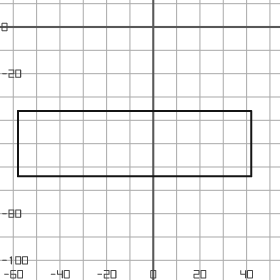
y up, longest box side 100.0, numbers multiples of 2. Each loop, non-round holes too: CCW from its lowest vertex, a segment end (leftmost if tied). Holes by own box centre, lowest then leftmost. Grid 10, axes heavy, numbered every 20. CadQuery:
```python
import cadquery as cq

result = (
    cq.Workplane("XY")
    .moveTo(-58.0, -64.0)
    .lineTo(42.0, -64.0)
    .lineTo(42.0, -36.0)
    .lineTo(-58.0, -36.0)
    .close()
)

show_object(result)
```